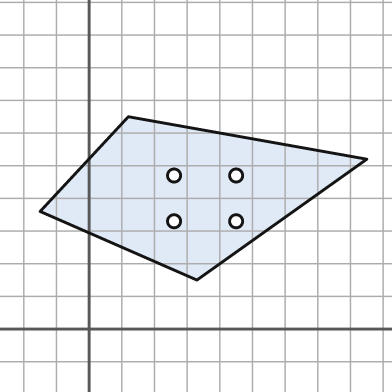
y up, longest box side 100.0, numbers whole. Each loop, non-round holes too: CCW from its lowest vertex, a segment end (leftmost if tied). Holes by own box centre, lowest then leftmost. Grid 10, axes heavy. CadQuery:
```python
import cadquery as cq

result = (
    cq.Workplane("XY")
    .moveTo(33.0, 15.0)
    .lineTo(85.0, 52.0)
    .lineTo(12.0, 65.0)
    .lineTo(-15.0, 36.0)
    .close()
    .moveTo(26.0, 33.0)
    .circle(2.0)
    .moveTo(45.0, 33.0)
    .circle(2.0)
    .moveTo(26.0, 47.0)
    .circle(2.0)
    .moveTo(45.0, 47.0)
    .circle(2.0)
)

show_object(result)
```